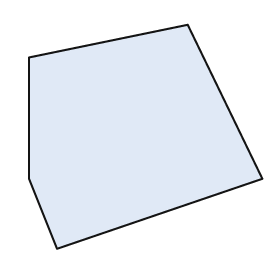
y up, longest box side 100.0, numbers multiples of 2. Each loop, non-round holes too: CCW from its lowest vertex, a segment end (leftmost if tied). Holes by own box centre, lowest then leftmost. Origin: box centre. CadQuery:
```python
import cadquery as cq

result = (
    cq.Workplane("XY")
    .moveTo(-38.0, -48.0)
    .lineTo(50.0, -18.0)
    .lineTo(18.0, 48.0)
    .lineTo(-50.0, 34.0)
    .lineTo(-50.0, -18.0)
    .close()
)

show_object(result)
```